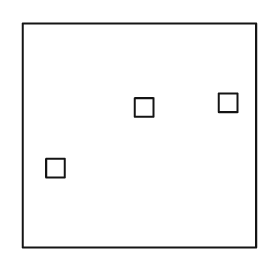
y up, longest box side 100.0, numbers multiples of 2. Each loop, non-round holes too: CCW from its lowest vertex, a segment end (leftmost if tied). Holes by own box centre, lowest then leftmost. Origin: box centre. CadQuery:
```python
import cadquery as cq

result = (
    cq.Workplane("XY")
    .moveTo(-50.0, -48.0)
    .lineTo(50.0, -48.0)
    .lineTo(50.0, 48.0)
    .lineTo(-50.0, 48.0)
    .close()
    .moveTo(-40.0, -18.0)
    .lineTo(-32.0, -18.0)
    .lineTo(-32.0, -10.0)
    .lineTo(-40.0, -10.0)
    .close()
    .moveTo(-2.0, 8.0)
    .lineTo(6.0, 8.0)
    .lineTo(6.0, 16.0)
    .lineTo(-2.0, 16.0)
    .close()
    .moveTo(34.0, 10.0)
    .lineTo(42.0, 10.0)
    .lineTo(42.0, 18.0)
    .lineTo(34.0, 18.0)
    .close()
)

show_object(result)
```